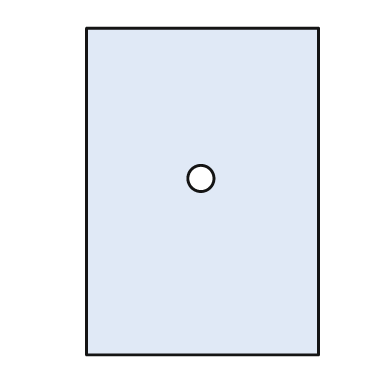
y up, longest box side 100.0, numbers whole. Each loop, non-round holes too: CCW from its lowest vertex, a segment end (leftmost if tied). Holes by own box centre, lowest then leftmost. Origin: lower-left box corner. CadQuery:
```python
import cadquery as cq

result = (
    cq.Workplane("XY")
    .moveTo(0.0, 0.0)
    .lineTo(71.0, 0.0)
    .lineTo(71.0, 100.0)
    .lineTo(0.0, 100.0)
    .close()
    .moveTo(35.0, 54.0)
    .circle(4.0)
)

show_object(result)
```